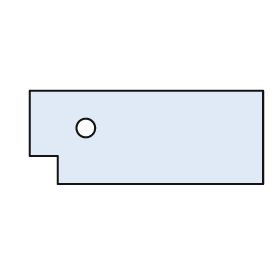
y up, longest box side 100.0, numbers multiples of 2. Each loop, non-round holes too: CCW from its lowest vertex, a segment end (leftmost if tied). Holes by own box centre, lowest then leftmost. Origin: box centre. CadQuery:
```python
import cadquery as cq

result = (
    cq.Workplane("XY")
    .moveTo(-38.0, -20.0)
    .lineTo(50.0, -20.0)
    .lineTo(50.0, 20.0)
    .lineTo(-50.0, 20.0)
    .lineTo(-50.0, -8.0)
    .lineTo(-38.0, -8.0)
    .close()
    .moveTo(-26.0, 4.0)
    .circle(4.0)
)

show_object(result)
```